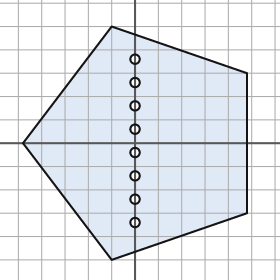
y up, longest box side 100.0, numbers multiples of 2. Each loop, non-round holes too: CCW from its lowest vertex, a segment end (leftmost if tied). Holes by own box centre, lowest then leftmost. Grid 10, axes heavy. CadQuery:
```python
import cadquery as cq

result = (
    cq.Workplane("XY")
    .moveTo(-10.0, -50.0)
    .lineTo(48.0, -30.0)
    .lineTo(48.0, 30.0)
    .lineTo(-10.0, 50.0)
    .lineTo(-48.0, 0.0)
    .close()
    .moveTo(0.0, -34.0)
    .circle(2.0)
    .moveTo(0.0, -24.0)
    .circle(2.0)
    .moveTo(0.0, -14.0)
    .circle(2.0)
    .moveTo(0.0, -4.0)
    .circle(2.0)
    .moveTo(0.0, 6.0)
    .circle(2.0)
    .moveTo(0.0, 16.0)
    .circle(2.0)
    .moveTo(0.0, 26.0)
    .circle(2.0)
    .moveTo(0.0, 36.0)
    .circle(2.0)
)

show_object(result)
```